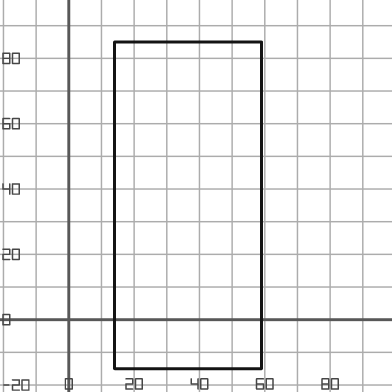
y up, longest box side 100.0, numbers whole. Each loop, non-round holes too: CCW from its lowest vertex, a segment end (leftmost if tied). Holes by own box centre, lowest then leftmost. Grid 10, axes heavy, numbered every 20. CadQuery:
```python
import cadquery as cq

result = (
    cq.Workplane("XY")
    .moveTo(14.0, -15.0)
    .lineTo(59.0, -15.0)
    .lineTo(59.0, 85.0)
    .lineTo(14.0, 85.0)
    .close()
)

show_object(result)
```